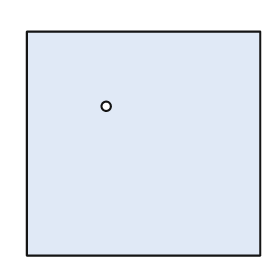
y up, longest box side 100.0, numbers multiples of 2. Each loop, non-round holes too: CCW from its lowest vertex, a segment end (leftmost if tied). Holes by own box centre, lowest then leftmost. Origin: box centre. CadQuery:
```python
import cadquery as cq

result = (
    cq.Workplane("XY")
    .moveTo(-50.0, -48.0)
    .lineTo(50.0, -48.0)
    .lineTo(50.0, 48.0)
    .lineTo(-50.0, 48.0)
    .close()
    .moveTo(-16.0, 16.0)
    .circle(2.0)
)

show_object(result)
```